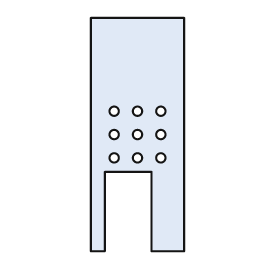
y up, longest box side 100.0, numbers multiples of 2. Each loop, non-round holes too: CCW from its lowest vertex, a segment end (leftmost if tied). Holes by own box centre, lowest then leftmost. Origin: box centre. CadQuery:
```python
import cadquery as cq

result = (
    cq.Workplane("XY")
    .moveTo(-20.0, -50.0)
    .lineTo(-14.0, -50.0)
    .lineTo(-14.0, -16.0)
    .lineTo(6.0, -16.0)
    .lineTo(6.0, -50.0)
    .lineTo(20.0, -50.0)
    .lineTo(20.0, 50.0)
    .lineTo(-20.0, 50.0)
    .close()
    .moveTo(-10.0, -10.0)
    .circle(2.0)
    .moveTo(0.0, -10.0)
    .circle(2.0)
    .moveTo(10.0, -10.0)
    .circle(2.0)
    .moveTo(-10.0, 0.0)
    .circle(2.0)
    .moveTo(0.0, 0.0)
    .circle(2.0)
    .moveTo(10.0, 0.0)
    .circle(2.0)
    .moveTo(-10.0, 10.0)
    .circle(2.0)
    .moveTo(0.0, 10.0)
    .circle(2.0)
    .moveTo(10.0, 10.0)
    .circle(2.0)
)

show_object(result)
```